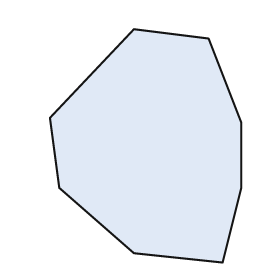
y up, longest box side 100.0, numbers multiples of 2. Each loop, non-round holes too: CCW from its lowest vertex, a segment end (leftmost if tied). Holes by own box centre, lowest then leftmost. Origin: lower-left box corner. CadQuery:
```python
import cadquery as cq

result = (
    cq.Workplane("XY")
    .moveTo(74.0, 0.0)
    .lineTo(82.0, 32.0)
    .lineTo(82.0, 60.0)
    .lineTo(68.0, 96.0)
    .lineTo(36.0, 100.0)
    .lineTo(0.0, 62.0)
    .lineTo(4.0, 32.0)
    .lineTo(36.0, 4.0)
    .close()
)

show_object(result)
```